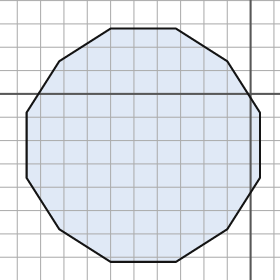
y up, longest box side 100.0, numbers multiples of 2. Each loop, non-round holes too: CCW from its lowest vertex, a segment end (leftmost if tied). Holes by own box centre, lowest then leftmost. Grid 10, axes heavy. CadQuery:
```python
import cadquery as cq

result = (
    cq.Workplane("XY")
    .moveTo(-60.0, -72.0)
    .lineTo(-32.0, -72.0)
    .lineTo(-10.0, -58.0)
    .lineTo(4.0, -36.0)
    .lineTo(4.0, -8.0)
    .lineTo(-10.0, 14.0)
    .lineTo(-32.0, 28.0)
    .lineTo(-60.0, 28.0)
    .lineTo(-82.0, 14.0)
    .lineTo(-96.0, -8.0)
    .lineTo(-96.0, -36.0)
    .lineTo(-82.0, -58.0)
    .close()
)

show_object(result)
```